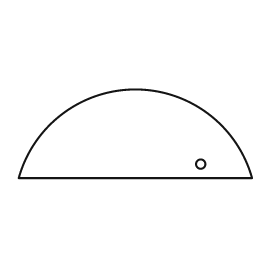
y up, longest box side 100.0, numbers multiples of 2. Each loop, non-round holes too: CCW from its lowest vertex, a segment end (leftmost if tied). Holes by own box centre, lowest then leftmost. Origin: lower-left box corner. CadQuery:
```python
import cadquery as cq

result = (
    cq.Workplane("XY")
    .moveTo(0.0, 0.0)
    .lineTo(100.0, 0.0)
    .threePointArc((50.0, 38.0), (0.0, 0.0))
    .close()
    .moveTo(78.0, 6.0)
    .circle(2.0)
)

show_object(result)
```